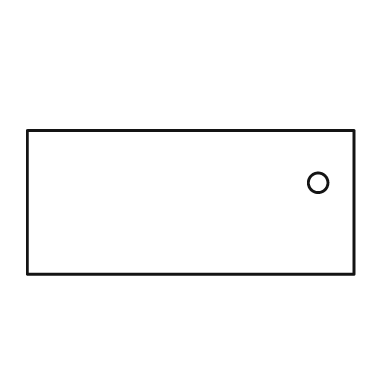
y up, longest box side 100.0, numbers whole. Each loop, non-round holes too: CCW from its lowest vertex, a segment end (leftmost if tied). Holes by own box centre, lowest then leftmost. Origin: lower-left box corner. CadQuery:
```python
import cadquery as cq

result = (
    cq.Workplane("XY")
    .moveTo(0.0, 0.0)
    .lineTo(100.0, 0.0)
    .lineTo(100.0, 44.0)
    .lineTo(0.0, 44.0)
    .close()
    .moveTo(89.0, 28.0)
    .circle(3.0)
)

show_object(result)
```